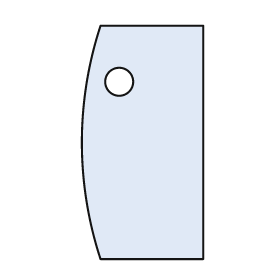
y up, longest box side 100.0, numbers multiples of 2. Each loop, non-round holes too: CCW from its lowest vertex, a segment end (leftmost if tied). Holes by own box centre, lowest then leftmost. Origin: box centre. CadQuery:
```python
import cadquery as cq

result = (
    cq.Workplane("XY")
    .moveTo(-18.0, -50.0)
    .lineTo(26.0, -50.0)
    .lineTo(26.0, 50.0)
    .lineTo(-18.0, 50.0)
    .threePointArc((-26.0, 0.0), (-18.0, -50.0))
    .close()
    .moveTo(-10.0, 26.0)
    .circle(6.0)
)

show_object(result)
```